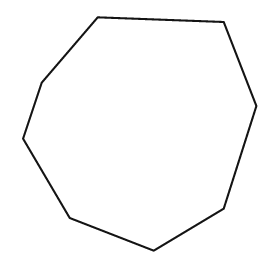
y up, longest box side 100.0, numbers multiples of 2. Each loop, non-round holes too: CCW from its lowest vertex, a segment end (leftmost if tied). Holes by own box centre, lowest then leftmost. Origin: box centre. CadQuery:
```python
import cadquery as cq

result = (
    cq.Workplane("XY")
    .moveTo(6.0, -50.0)
    .lineTo(36.0, -32.0)
    .lineTo(50.0, 12.0)
    .lineTo(36.0, 48.0)
    .lineTo(-18.0, 50.0)
    .lineTo(-42.0, 22.0)
    .lineTo(-50.0, -2.0)
    .lineTo(-30.0, -36.0)
    .close()
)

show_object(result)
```